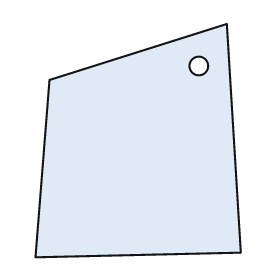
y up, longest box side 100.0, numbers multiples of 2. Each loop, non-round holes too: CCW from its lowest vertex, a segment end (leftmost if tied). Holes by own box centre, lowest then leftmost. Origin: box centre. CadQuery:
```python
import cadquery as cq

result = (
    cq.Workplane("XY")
    .moveTo(-44.0, -50.0)
    .lineTo(44.0, -48.0)
    .lineTo(38.0, 50.0)
    .lineTo(-38.0, 26.0)
    .close()
    .moveTo(26.0, 32.0)
    .circle(4.0)
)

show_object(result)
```